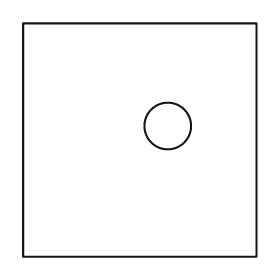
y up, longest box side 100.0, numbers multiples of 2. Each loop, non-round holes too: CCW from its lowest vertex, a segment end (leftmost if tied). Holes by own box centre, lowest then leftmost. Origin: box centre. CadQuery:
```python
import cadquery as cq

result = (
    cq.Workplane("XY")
    .moveTo(-50.0, -50.0)
    .lineTo(50.0, -50.0)
    .lineTo(50.0, 50.0)
    .lineTo(-50.0, 50.0)
    .close()
    .moveTo(12.0, 6.0)
    .circle(10.0)
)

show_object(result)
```